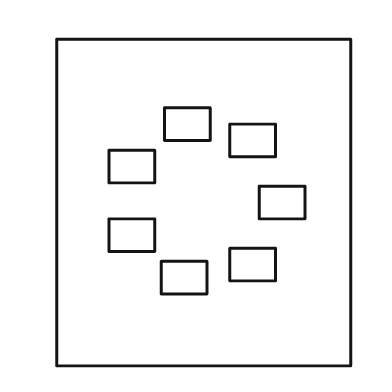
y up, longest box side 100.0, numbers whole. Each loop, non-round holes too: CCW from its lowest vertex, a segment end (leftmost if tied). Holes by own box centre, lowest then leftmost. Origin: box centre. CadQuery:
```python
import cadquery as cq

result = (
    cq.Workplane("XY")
    .moveTo(-45.0, -50.0)
    .lineTo(45.0, -50.0)
    .lineTo(45.0, 50.0)
    .lineTo(-45.0, 50.0)
    .close()
    .moveTo(-13.0, -28.0)
    .lineTo(1.0, -28.0)
    .lineTo(1.0, -18.0)
    .lineTo(-13.0, -18.0)
    .close()
    .moveTo(8.0, -24.0)
    .lineTo(22.0, -24.0)
    .lineTo(22.0, -14.0)
    .lineTo(8.0, -14.0)
    .close()
    .moveTo(-29.0, -15.0)
    .lineTo(-15.0, -15.0)
    .lineTo(-15.0, -5.0)
    .lineTo(-29.0, -5.0)
    .close()
    .moveTo(17.0, -5.0)
    .lineTo(31.0, -5.0)
    .lineTo(31.0, 5.0)
    .lineTo(17.0, 5.0)
    .close()
    .moveTo(-29.0, 6.0)
    .lineTo(-15.0, 6.0)
    .lineTo(-15.0, 16.0)
    .lineTo(-29.0, 16.0)
    .close()
    .moveTo(8.0, 14.0)
    .lineTo(22.0, 14.0)
    .lineTo(22.0, 24.0)
    .lineTo(8.0, 24.0)
    .close()
    .moveTo(-12.0, 19.0)
    .lineTo(2.0, 19.0)
    .lineTo(2.0, 29.0)
    .lineTo(-12.0, 29.0)
    .close()
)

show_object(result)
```